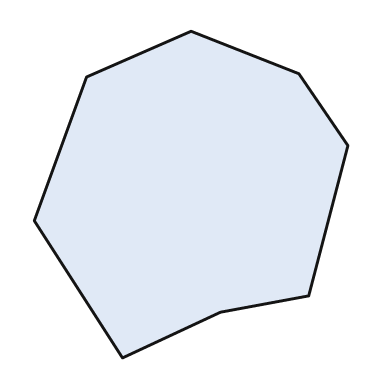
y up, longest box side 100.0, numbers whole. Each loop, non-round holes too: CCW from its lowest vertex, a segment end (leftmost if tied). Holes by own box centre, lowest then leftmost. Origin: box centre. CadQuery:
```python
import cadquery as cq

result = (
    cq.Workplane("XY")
    .moveTo(-21.0, -50.0)
    .lineTo(9.0, -36.0)
    .lineTo(36.0, -31.0)
    .lineTo(48.0, 15.0)
    .lineTo(33.0, 37.0)
    .lineTo(0.0, 50.0)
    .lineTo(-32.0, 36.0)
    .lineTo(-48.0, -8.0)
    .close()
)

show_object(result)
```